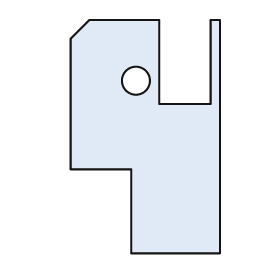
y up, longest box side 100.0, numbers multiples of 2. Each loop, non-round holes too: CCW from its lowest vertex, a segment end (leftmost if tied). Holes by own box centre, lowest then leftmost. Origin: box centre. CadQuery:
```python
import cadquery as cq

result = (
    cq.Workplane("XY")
    .moveTo(-6.0, -50.0)
    .lineTo(32.0, -50.0)
    .lineTo(32.0, 50.0)
    .lineTo(28.0, 50.0)
    .lineTo(28.0, 14.0)
    .lineTo(6.0, 14.0)
    .lineTo(6.0, 50.0)
    .lineTo(-24.0, 50.0)
    .lineTo(-32.0, 42.0)
    .lineTo(-32.0, -14.0)
    .lineTo(-6.0, -14.0)
    .close()
    .moveTo(-4.0, 24.0)
    .circle(6.0)
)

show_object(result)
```